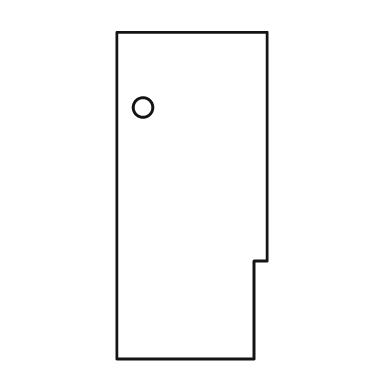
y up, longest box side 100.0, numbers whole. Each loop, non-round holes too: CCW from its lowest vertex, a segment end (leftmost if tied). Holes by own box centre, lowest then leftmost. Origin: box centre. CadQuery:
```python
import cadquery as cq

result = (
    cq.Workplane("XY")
    .moveTo(-23.0, -50.0)
    .lineTo(19.0, -50.0)
    .lineTo(19.0, -20.0)
    .lineTo(23.0, -20.0)
    .lineTo(23.0, 50.0)
    .lineTo(-23.0, 50.0)
    .close()
    .moveTo(-15.0, 27.0)
    .circle(3.0)
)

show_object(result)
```